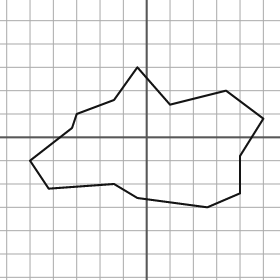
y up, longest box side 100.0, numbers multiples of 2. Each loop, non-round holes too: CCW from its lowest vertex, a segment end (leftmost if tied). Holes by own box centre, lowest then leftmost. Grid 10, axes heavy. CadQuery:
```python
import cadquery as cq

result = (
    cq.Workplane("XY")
    .moveTo(26.0, -30.0)
    .lineTo(40.0, -24.0)
    .lineTo(40.0, -8.0)
    .lineTo(50.0, 8.0)
    .lineTo(34.0, 20.0)
    .lineTo(10.0, 14.0)
    .lineTo(-4.0, 30.0)
    .lineTo(-14.0, 16.0)
    .lineTo(-30.0, 10.0)
    .lineTo(-32.0, 4.0)
    .lineTo(-50.0, -10.0)
    .lineTo(-42.0, -22.0)
    .lineTo(-14.0, -20.0)
    .lineTo(-4.0, -26.0)
    .close()
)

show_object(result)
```